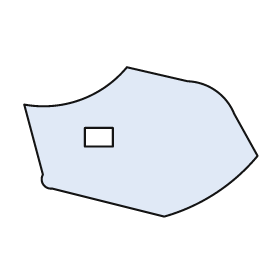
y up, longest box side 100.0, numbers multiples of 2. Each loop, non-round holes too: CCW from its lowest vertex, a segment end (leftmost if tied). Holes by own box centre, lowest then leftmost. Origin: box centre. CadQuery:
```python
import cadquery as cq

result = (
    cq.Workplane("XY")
    .moveTo(10.0, -32.0)
    .threePointArc((32.0, -22.0), (50.0, -6.0))
    .lineTo(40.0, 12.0)
    .threePointArc((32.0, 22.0), (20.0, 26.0))
    .lineTo(-6.0, 32.0)
    .threePointArc((-26.0, 18.0), (-50.0, 16.0))
    .lineTo(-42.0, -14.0)
    .threePointArc((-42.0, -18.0), (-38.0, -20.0))
    .close()
    .moveTo(-24.0, -2.0)
    .lineTo(-12.0, -2.0)
    .lineTo(-12.0, 6.0)
    .lineTo(-24.0, 6.0)
    .close()
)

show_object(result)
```